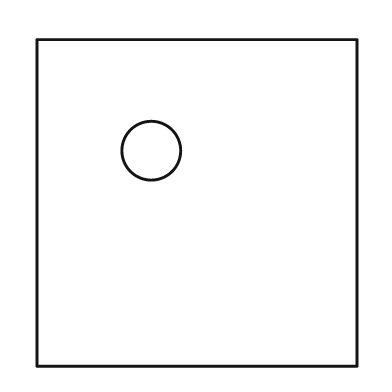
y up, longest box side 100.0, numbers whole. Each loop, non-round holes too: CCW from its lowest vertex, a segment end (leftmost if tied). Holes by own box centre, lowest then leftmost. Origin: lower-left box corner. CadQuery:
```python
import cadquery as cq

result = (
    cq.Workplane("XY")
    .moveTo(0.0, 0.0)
    .lineTo(98.0, 0.0)
    .lineTo(98.0, 100.0)
    .lineTo(0.0, 100.0)
    .close()
    .moveTo(35.0, 66.0)
    .circle(9.0)
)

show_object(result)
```